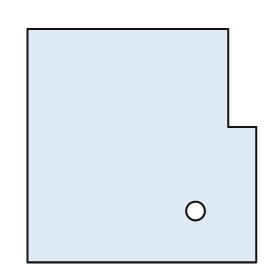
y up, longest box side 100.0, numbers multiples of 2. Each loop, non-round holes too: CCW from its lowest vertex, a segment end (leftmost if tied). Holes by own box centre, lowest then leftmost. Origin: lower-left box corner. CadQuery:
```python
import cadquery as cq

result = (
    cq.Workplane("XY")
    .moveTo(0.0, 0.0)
    .lineTo(98.0, 0.0)
    .lineTo(98.0, 58.0)
    .lineTo(86.0, 58.0)
    .lineTo(86.0, 100.0)
    .lineTo(0.0, 100.0)
    .close()
    .moveTo(72.0, 22.0)
    .circle(4.0)
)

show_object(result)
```